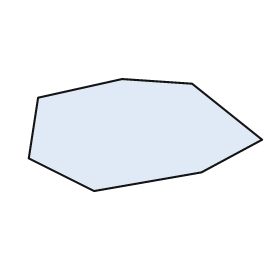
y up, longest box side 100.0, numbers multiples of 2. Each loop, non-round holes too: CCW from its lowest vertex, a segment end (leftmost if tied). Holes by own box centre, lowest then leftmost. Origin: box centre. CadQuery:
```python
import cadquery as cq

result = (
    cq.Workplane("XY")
    .moveTo(-22.0, -24.0)
    .lineTo(24.0, -16.0)
    .lineTo(50.0, -2.0)
    .lineTo(20.0, 22.0)
    .lineTo(-10.0, 24.0)
    .lineTo(-46.0, 16.0)
    .lineTo(-50.0, -10.0)
    .close()
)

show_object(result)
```